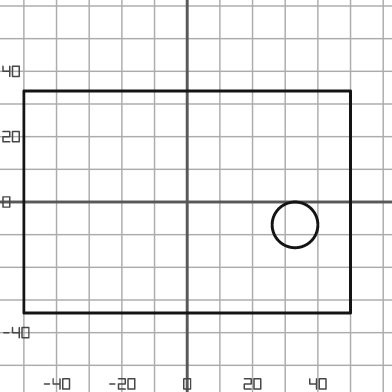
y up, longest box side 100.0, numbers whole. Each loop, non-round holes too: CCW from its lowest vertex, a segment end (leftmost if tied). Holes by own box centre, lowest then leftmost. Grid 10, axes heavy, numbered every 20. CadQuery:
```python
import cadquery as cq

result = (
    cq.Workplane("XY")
    .moveTo(-50.0, -34.0)
    .lineTo(50.0, -34.0)
    .lineTo(50.0, 34.0)
    .lineTo(-50.0, 34.0)
    .close()
    .moveTo(33.0, -7.0)
    .circle(7.0)
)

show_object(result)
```